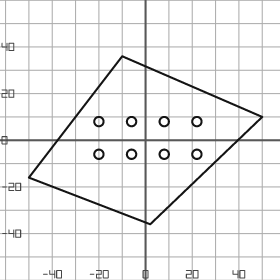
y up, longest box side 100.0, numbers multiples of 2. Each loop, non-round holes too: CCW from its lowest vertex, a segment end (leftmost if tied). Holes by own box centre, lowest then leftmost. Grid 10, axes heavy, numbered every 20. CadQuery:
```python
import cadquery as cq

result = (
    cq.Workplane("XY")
    .moveTo(2.0, -36.0)
    .lineTo(50.0, 10.0)
    .lineTo(-10.0, 36.0)
    .lineTo(-50.0, -16.0)
    .close()
    .moveTo(-20.0, -6.0)
    .circle(2.0)
    .moveTo(-6.0, -6.0)
    .circle(2.0)
    .moveTo(8.0, -6.0)
    .circle(2.0)
    .moveTo(22.0, -6.0)
    .circle(2.0)
    .moveTo(-20.0, 8.0)
    .circle(2.0)
    .moveTo(-6.0, 8.0)
    .circle(2.0)
    .moveTo(8.0, 8.0)
    .circle(2.0)
    .moveTo(22.0, 8.0)
    .circle(2.0)
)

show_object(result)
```